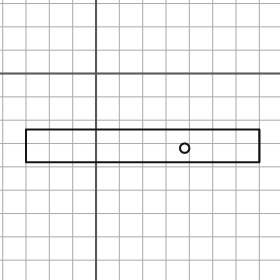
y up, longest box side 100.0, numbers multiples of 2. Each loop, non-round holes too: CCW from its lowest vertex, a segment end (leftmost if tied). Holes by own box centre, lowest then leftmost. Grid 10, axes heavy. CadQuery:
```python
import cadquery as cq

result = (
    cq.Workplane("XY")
    .moveTo(-30.0, -38.0)
    .lineTo(70.0, -38.0)
    .lineTo(70.0, -24.0)
    .lineTo(-30.0, -24.0)
    .close()
    .moveTo(38.0, -32.0)
    .circle(2.0)
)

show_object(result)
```